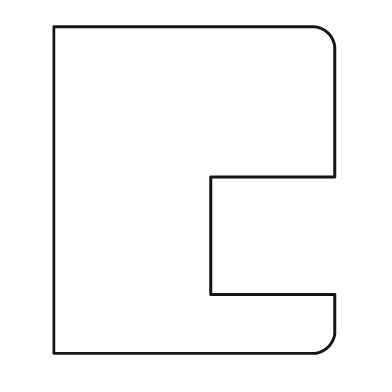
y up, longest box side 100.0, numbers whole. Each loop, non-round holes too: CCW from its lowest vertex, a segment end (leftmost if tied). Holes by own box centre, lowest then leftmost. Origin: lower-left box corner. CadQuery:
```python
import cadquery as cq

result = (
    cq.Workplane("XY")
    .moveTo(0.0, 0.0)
    .lineTo(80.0, 0.0)
    .threePointArc((84.0, 2.0), (86.0, 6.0))
    .lineTo(86.0, 18.0)
    .lineTo(48.0, 18.0)
    .lineTo(48.0, 54.0)
    .lineTo(86.0, 54.0)
    .lineTo(86.0, 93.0)
    .threePointArc((84.0, 98.0), (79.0, 100.0))
    .lineTo(0.0, 100.0)
    .close()
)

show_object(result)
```